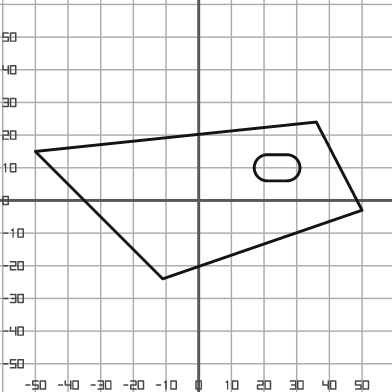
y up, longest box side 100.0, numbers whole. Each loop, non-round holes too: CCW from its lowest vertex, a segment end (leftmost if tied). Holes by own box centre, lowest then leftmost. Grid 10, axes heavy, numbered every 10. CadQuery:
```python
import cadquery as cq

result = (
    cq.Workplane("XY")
    .moveTo(-11.0, -24.0)
    .lineTo(50.0, -3.0)
    .lineTo(36.0, 24.0)
    .lineTo(-50.0, 15.0)
    .close()
    .moveTo(21.0, 6.0)
    .lineTo(27.0, 6.0)
    .threePointArc((31.0, 10.0), (27.0, 14.0))
    .lineTo(21.0, 14.0)
    .threePointArc((17.0, 10.0), (21.0, 6.0))
    .close()
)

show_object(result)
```